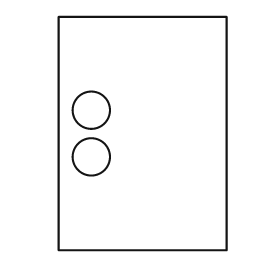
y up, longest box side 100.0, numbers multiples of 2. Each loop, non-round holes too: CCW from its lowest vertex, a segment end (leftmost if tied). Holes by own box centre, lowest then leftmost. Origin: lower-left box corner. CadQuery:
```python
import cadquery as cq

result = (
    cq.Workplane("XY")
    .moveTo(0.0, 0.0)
    .lineTo(72.0, 0.0)
    .lineTo(72.0, 100.0)
    .lineTo(0.0, 100.0)
    .close()
    .moveTo(14.0, 40.0)
    .circle(8.0)
    .moveTo(14.0, 60.0)
    .circle(8.0)
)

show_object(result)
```